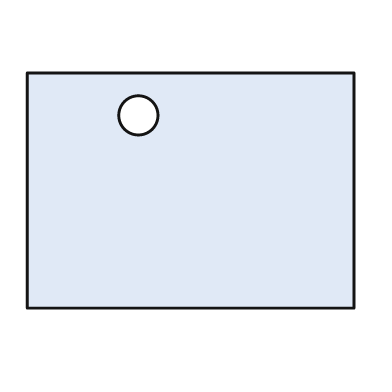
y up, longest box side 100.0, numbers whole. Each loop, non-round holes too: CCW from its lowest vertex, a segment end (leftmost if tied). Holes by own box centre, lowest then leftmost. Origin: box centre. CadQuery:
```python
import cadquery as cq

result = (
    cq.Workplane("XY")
    .moveTo(-50.0, -36.0)
    .lineTo(50.0, -36.0)
    .lineTo(50.0, 36.0)
    .lineTo(-50.0, 36.0)
    .close()
    .moveTo(-16.0, 23.0)
    .circle(6.0)
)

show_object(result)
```